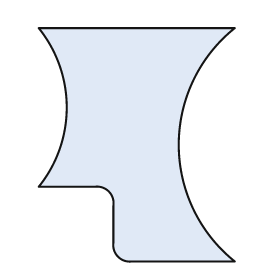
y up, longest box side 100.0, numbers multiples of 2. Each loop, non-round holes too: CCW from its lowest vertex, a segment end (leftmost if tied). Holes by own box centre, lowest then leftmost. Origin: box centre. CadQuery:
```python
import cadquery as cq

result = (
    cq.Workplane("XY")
    .moveTo(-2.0, -50.0)
    .lineTo(42.0, -50.0)
    .threePointArc((18.0, 0.0), (42.0, 50.0))
    .lineTo(-42.0, 50.0)
    .threePointArc((-30.0, 16.0), (-42.0, -18.0))
    .lineTo(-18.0, -18.0)
    .threePointArc((-12.0, -20.0), (-10.0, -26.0))
    .lineTo(-10.0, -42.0)
    .threePointArc((-8.0, -48.0), (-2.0, -50.0))
    .close()
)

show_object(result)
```